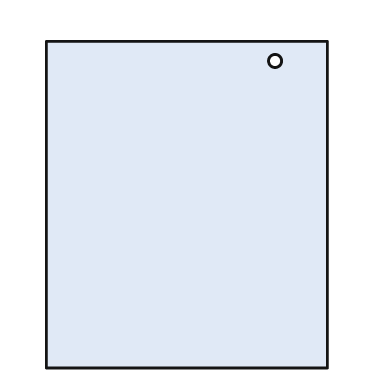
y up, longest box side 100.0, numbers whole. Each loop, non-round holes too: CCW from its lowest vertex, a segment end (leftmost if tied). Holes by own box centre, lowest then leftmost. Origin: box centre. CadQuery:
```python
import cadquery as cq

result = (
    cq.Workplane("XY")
    .moveTo(-43.0, -50.0)
    .lineTo(43.0, -50.0)
    .lineTo(43.0, 50.0)
    .lineTo(-43.0, 50.0)
    .close()
    .moveTo(27.0, 44.0)
    .circle(2.0)
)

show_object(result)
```